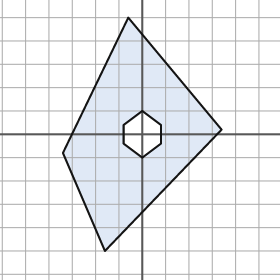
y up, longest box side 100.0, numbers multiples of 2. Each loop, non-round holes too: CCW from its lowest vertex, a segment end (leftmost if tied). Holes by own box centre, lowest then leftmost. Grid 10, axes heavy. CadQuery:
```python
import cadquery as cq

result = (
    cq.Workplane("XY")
    .moveTo(-16.0, -50.0)
    .lineTo(34.0, 2.0)
    .lineTo(-6.0, 50.0)
    .lineTo(-34.0, -8.0)
    .close()
    .moveTo(0.0, -10.0)
    .lineTo(8.0, -4.0)
    .lineTo(8.0, 4.0)
    .lineTo(0.0, 10.0)
    .lineTo(-8.0, 4.0)
    .lineTo(-8.0, -4.0)
    .close()
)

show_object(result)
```